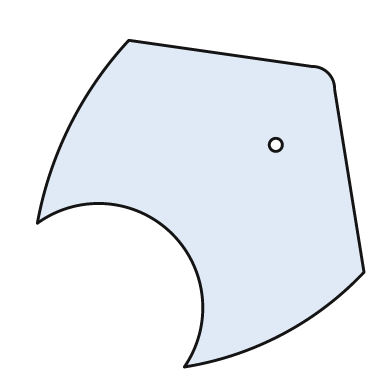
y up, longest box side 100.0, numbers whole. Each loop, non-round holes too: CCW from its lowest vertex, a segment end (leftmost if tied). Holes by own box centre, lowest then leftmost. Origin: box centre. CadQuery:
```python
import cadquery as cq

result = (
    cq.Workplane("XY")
    .moveTo(-5.0, -50.0)
    .threePointArc((25.0, -40.0), (50.0, -21.0))
    .lineTo(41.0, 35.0)
    .threePointArc((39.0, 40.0), (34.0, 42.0))
    .lineTo(-22.0, 50.0)
    .threePointArc((-40.0, 24.0), (-50.0, -6.0))
    .threePointArc((-9.0, -9.0), (-5.0, -50.0))
    .close()
    .moveTo(23.0, 18.0)
    .circle(2.0)
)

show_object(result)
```